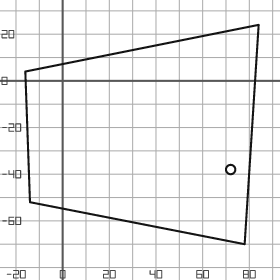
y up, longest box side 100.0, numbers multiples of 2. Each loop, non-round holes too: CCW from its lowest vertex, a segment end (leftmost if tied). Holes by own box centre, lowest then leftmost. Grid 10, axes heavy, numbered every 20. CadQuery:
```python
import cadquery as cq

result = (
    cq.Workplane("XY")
    .moveTo(78.0, -70.0)
    .lineTo(84.0, 24.0)
    .lineTo(-16.0, 4.0)
    .lineTo(-14.0, -52.0)
    .close()
    .moveTo(72.0, -38.0)
    .circle(2.0)
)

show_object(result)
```